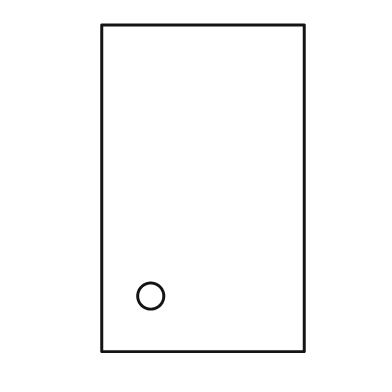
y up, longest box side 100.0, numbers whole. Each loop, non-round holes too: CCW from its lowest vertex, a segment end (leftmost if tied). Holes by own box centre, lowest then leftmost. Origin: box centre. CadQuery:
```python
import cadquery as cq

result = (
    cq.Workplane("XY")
    .moveTo(-31.0, -50.0)
    .lineTo(31.0, -50.0)
    .lineTo(31.0, 50.0)
    .lineTo(-31.0, 50.0)
    .close()
    .moveTo(-16.0, -33.0)
    .circle(4.0)
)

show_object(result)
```